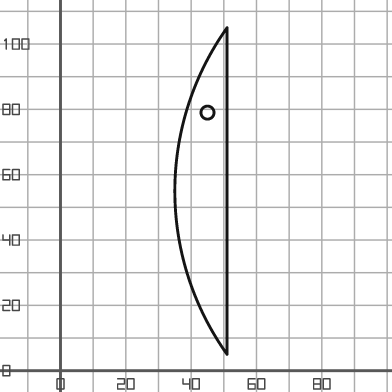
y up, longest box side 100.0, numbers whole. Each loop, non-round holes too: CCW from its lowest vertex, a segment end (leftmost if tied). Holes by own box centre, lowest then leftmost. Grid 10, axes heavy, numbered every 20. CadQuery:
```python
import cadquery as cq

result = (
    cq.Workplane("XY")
    .moveTo(51.0, 5.0)
    .lineTo(51.0, 105.0)
    .threePointArc((35.0, 55.0), (51.0, 5.0))
    .close()
    .moveTo(45.0, 79.0)
    .circle(2.0)
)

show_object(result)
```